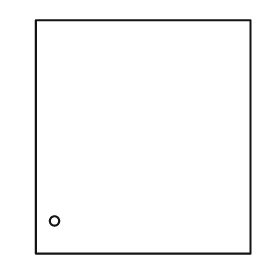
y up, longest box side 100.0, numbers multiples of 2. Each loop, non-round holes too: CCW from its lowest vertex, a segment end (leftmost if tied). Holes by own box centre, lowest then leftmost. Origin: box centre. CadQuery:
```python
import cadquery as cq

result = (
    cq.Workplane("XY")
    .moveTo(-46.0, -50.0)
    .lineTo(46.0, -50.0)
    .lineTo(46.0, 50.0)
    .lineTo(-46.0, 50.0)
    .close()
    .moveTo(-38.0, -36.0)
    .circle(2.0)
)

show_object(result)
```